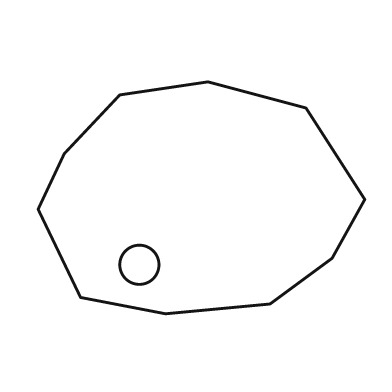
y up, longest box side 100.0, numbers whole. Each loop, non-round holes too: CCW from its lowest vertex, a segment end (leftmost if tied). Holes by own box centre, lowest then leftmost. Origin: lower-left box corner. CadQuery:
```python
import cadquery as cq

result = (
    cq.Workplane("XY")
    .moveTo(39.0, 0.0)
    .lineTo(71.0, 3.0)
    .lineTo(90.0, 17.0)
    .lineTo(100.0, 35.0)
    .lineTo(82.0, 63.0)
    .lineTo(52.0, 71.0)
    .lineTo(25.0, 67.0)
    .lineTo(8.0, 49.0)
    .lineTo(0.0, 32.0)
    .lineTo(13.0, 5.0)
    .close()
    .moveTo(31.0, 15.0)
    .circle(6.0)
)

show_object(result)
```